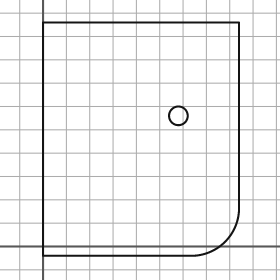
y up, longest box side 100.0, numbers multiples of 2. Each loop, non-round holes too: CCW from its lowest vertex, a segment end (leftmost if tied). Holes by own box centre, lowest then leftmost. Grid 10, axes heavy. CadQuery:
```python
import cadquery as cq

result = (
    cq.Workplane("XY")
    .moveTo(0.0, -4.0)
    .lineTo(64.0, -4.0)
    .threePointArc((78.0, 2.0), (84.0, 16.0))
    .lineTo(84.0, 96.0)
    .lineTo(0.0, 96.0)
    .close()
    .moveTo(58.0, 56.0)
    .circle(4.0)
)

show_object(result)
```